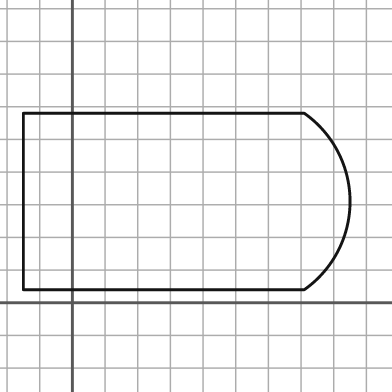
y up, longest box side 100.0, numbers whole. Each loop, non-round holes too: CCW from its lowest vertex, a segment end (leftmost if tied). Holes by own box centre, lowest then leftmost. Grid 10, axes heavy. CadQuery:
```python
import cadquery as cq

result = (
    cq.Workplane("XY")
    .moveTo(-15.0, 4.0)
    .lineTo(71.0, 4.0)
    .threePointArc((85.0, 31.0), (71.0, 58.0))
    .lineTo(-15.0, 58.0)
    .close()
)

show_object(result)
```